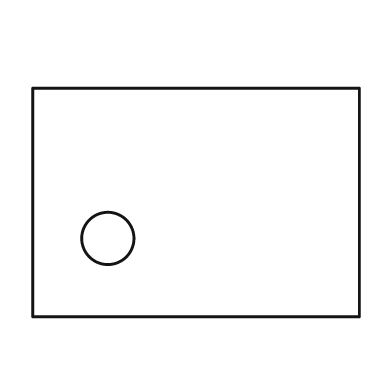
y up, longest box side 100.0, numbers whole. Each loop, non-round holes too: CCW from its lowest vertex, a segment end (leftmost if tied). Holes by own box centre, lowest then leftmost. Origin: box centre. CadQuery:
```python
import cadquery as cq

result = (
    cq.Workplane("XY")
    .moveTo(-50.0, -35.0)
    .lineTo(50.0, -35.0)
    .lineTo(50.0, 35.0)
    .lineTo(-50.0, 35.0)
    .close()
    .moveTo(-27.0, -11.0)
    .circle(8.0)
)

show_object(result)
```